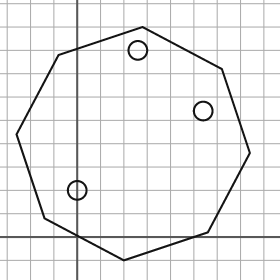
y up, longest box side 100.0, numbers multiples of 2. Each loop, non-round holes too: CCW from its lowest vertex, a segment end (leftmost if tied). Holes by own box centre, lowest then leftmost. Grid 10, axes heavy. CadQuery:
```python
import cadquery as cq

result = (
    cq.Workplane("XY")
    .moveTo(20.0, -10.0)
    .lineTo(56.0, 2.0)
    .lineTo(74.0, 36.0)
    .lineTo(62.0, 72.0)
    .lineTo(28.0, 90.0)
    .lineTo(-8.0, 78.0)
    .lineTo(-26.0, 44.0)
    .lineTo(-14.0, 8.0)
    .close()
    .moveTo(0.0, 20.0)
    .circle(4.0)
    .moveTo(54.0, 54.0)
    .circle(4.0)
    .moveTo(26.0, 80.0)
    .circle(4.0)
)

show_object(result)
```